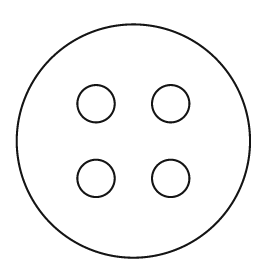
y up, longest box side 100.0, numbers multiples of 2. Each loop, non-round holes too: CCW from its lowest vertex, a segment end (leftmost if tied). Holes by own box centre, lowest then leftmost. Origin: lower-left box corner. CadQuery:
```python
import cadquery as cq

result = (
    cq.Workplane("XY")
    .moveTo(50.0, 50.0)
    .circle(50.0)
    .moveTo(34.0, 34.0)
    .circle(8.0)
    .moveTo(66.0, 34.0)
    .circle(8.0)
    .moveTo(34.0, 66.0)
    .circle(8.0)
    .moveTo(66.0, 66.0)
    .circle(8.0)
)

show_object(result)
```